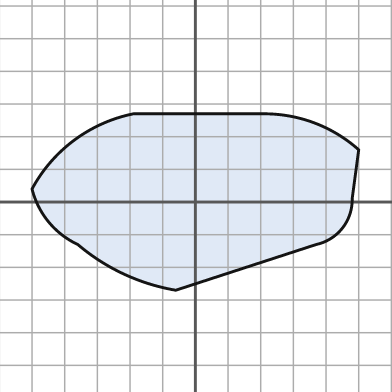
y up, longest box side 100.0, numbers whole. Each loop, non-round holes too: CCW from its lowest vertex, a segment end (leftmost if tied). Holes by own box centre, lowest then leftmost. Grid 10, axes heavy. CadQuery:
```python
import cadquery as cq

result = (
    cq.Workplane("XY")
    .moveTo(-6.0, -27.0)
    .lineTo(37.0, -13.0)
    .threePointArc((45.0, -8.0), (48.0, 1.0))
    .lineTo(50.0, 16.0)
    .threePointArc((37.0, 24.0), (22.0, 27.0))
    .lineTo(-19.0, 27.0)
    .threePointArc((-37.0, 19.0), (-50.0, 4.0))
    .threePointArc((-45.0, -6.0), (-36.0, -13.0))
    .threePointArc((-22.0, -22.0), (-6.0, -27.0))
    .close()
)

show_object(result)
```